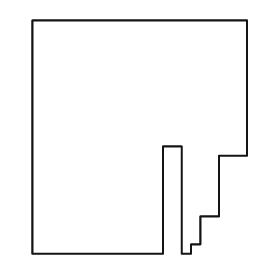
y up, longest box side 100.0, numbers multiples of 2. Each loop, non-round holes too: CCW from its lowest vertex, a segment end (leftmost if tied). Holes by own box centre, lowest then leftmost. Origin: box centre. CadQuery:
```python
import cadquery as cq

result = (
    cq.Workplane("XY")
    .moveTo(-46.0, -50.0)
    .lineTo(10.0, -50.0)
    .lineTo(10.0, -4.0)
    .lineTo(18.0, -4.0)
    .lineTo(18.0, -50.0)
    .lineTo(22.0, -50.0)
    .lineTo(22.0, -46.0)
    .lineTo(26.0, -46.0)
    .lineTo(26.0, -34.0)
    .lineTo(34.0, -34.0)
    .lineTo(34.0, -8.0)
    .lineTo(46.0, -8.0)
    .lineTo(46.0, 50.0)
    .lineTo(-46.0, 50.0)
    .close()
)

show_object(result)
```